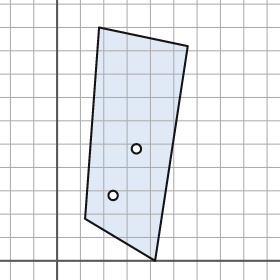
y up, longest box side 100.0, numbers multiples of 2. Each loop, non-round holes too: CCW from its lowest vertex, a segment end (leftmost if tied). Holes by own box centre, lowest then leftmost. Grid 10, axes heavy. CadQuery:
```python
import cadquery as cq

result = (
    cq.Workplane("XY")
    .moveTo(42.0, 0.0)
    .lineTo(56.0, 92.0)
    .lineTo(18.0, 100.0)
    .lineTo(12.0, 18.0)
    .close()
    .moveTo(24.0, 28.0)
    .circle(2.0)
    .moveTo(34.0, 48.0)
    .circle(2.0)
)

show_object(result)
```